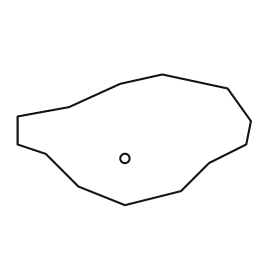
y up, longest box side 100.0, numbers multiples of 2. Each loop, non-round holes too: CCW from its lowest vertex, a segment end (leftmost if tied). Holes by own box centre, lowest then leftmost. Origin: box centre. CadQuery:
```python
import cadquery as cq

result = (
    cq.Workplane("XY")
    .moveTo(-4.0, -28.0)
    .lineTo(20.0, -22.0)
    .lineTo(32.0, -10.0)
    .lineTo(48.0, -2.0)
    .lineTo(50.0, 8.0)
    .lineTo(40.0, 22.0)
    .lineTo(12.0, 28.0)
    .lineTo(-6.0, 24.0)
    .lineTo(-28.0, 14.0)
    .lineTo(-50.0, 10.0)
    .lineTo(-50.0, -2.0)
    .lineTo(-38.0, -6.0)
    .lineTo(-24.0, -20.0)
    .close()
    .moveTo(-4.0, -8.0)
    .circle(2.0)
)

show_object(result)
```